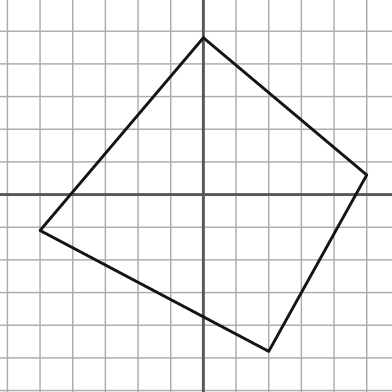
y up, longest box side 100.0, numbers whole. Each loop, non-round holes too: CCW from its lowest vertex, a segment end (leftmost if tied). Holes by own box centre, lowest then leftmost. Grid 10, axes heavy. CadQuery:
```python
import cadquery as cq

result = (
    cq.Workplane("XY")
    .moveTo(20.0, -48.0)
    .lineTo(50.0, 6.0)
    .lineTo(0.0, 48.0)
    .lineTo(-50.0, -11.0)
    .close()
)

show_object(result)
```